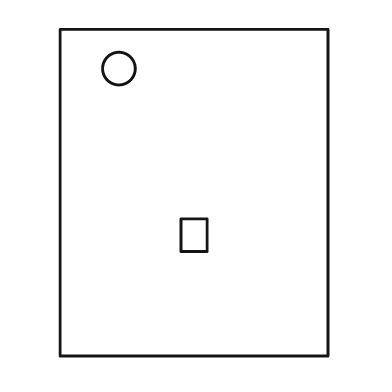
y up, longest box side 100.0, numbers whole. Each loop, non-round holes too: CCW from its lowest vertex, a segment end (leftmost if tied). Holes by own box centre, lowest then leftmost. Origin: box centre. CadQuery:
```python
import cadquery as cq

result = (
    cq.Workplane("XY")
    .moveTo(-41.0, -50.0)
    .lineTo(41.0, -50.0)
    .lineTo(41.0, 50.0)
    .lineTo(-41.0, 50.0)
    .close()
    .moveTo(-4.0, -18.0)
    .lineTo(4.0, -18.0)
    .lineTo(4.0, -8.0)
    .lineTo(-4.0, -8.0)
    .close()
    .moveTo(-23.0, 38.0)
    .circle(5.0)
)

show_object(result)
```